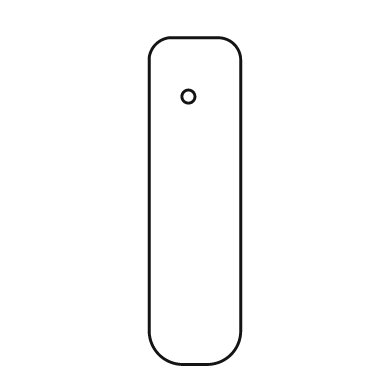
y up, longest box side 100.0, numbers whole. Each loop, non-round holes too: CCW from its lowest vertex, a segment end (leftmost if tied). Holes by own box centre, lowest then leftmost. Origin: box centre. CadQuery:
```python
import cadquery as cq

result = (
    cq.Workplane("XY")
    .moveTo(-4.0, -50.0)
    .lineTo(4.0, -50.0)
    .threePointArc((11.0, -47.0), (14.0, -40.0))
    .lineTo(14.0, 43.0)
    .threePointArc((12.0, 48.0), (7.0, 50.0))
    .lineTo(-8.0, 50.0)
    .threePointArc((-12.0, 48.0), (-14.0, 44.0))
    .lineTo(-14.0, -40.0)
    .threePointArc((-11.0, -47.0), (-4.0, -50.0))
    .close()
    .moveTo(-2.0, 32.0)
    .circle(2.0)
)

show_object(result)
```